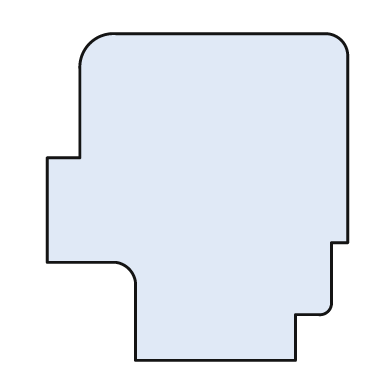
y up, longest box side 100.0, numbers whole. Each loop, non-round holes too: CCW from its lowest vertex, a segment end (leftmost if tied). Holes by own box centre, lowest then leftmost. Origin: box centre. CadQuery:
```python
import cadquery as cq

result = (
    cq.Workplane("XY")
    .moveTo(-19.0, -50.0)
    .lineTo(30.0, -50.0)
    .lineTo(30.0, -36.0)
    .lineTo(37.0, -36.0)
    .threePointArc((40.0, -35.0), (41.0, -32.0))
    .lineTo(41.0, -14.0)
    .lineTo(46.0, -14.0)
    .lineTo(46.0, 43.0)
    .threePointArc((44.0, 48.0), (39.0, 50.0))
    .lineTo(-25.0, 50.0)
    .threePointArc((-33.0, 47.0), (-36.0, 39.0))
    .lineTo(-36.0, 12.0)
    .lineTo(-46.0, 12.0)
    .lineTo(-46.0, -20.0)
    .lineTo(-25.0, -20.0)
    .threePointArc((-21.0, -22.0), (-19.0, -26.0))
    .close()
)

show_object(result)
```